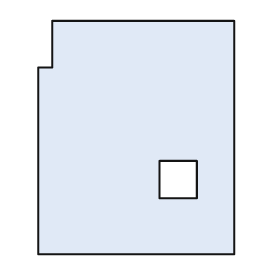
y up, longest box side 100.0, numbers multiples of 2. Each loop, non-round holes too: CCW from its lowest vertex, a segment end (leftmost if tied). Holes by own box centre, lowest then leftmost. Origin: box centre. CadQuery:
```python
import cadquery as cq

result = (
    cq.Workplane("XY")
    .moveTo(-42.0, -50.0)
    .lineTo(42.0, -50.0)
    .lineTo(42.0, 50.0)
    .lineTo(-36.0, 50.0)
    .lineTo(-36.0, 30.0)
    .lineTo(-42.0, 30.0)
    .close()
    .moveTo(10.0, -26.0)
    .lineTo(26.0, -26.0)
    .lineTo(26.0, -10.0)
    .lineTo(10.0, -10.0)
    .close()
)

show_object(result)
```